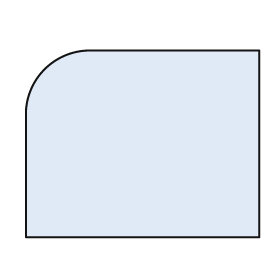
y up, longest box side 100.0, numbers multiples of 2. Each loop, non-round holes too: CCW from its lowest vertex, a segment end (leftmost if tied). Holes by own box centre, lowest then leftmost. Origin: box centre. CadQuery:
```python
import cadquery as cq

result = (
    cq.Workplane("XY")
    .moveTo(-50.0, -40.0)
    .lineTo(50.0, -40.0)
    .lineTo(50.0, 40.0)
    .lineTo(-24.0, 40.0)
    .threePointArc((-42.0, 32.0), (-50.0, 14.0))
    .close()
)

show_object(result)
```